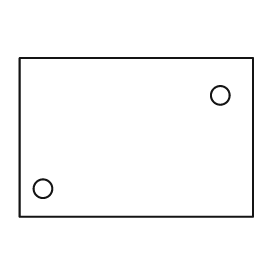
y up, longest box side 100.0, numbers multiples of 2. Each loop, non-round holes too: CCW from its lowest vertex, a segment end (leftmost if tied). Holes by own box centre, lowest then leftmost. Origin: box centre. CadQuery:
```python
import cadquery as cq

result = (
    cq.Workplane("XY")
    .moveTo(-50.0, -34.0)
    .lineTo(50.0, -34.0)
    .lineTo(50.0, 34.0)
    .lineTo(-50.0, 34.0)
    .close()
    .moveTo(-40.0, -22.0)
    .circle(4.0)
    .moveTo(36.0, 18.0)
    .circle(4.0)
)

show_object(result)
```